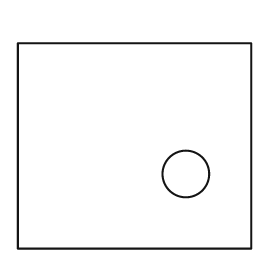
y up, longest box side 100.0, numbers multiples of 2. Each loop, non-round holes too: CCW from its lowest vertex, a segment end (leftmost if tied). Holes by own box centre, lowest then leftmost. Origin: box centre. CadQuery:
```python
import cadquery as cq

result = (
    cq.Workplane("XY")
    .moveTo(-50.0, -44.0)
    .lineTo(50.0, -44.0)
    .lineTo(50.0, 44.0)
    .lineTo(-50.0, 44.0)
    .close()
    .moveTo(22.0, -12.0)
    .circle(10.0)
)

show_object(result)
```